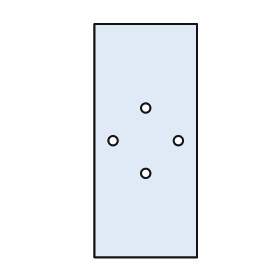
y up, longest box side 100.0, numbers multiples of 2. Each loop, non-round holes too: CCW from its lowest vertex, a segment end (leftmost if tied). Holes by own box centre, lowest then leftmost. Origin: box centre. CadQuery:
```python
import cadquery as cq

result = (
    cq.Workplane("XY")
    .moveTo(-22.0, -50.0)
    .lineTo(22.0, -50.0)
    .lineTo(22.0, 50.0)
    .lineTo(-22.0, 50.0)
    .close()
    .moveTo(0.0, -14.0)
    .circle(2.0)
    .moveTo(-14.0, 0.0)
    .circle(2.0)
    .moveTo(14.0, 0.0)
    .circle(2.0)
    .moveTo(0.0, 14.0)
    .circle(2.0)
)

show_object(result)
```